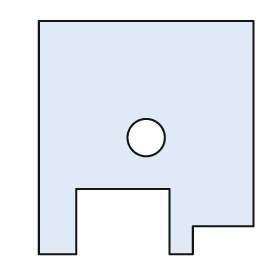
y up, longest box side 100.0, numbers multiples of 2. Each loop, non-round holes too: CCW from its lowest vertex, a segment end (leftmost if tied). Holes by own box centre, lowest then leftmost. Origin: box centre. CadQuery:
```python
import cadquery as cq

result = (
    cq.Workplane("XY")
    .moveTo(-46.0, -50.0)
    .lineTo(-30.0, -50.0)
    .lineTo(-30.0, -22.0)
    .lineTo(10.0, -22.0)
    .lineTo(10.0, -50.0)
    .lineTo(20.0, -50.0)
    .lineTo(20.0, -38.0)
    .lineTo(46.0, -38.0)
    .lineTo(46.0, 50.0)
    .lineTo(-46.0, 50.0)
    .close()
    .moveTo(0.0, 0.0)
    .circle(8.0)
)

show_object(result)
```